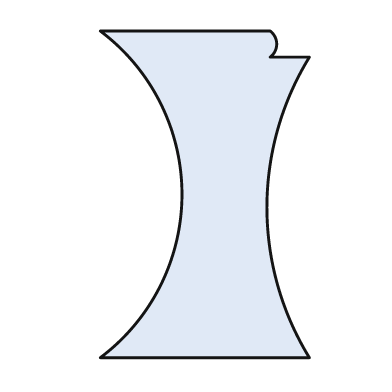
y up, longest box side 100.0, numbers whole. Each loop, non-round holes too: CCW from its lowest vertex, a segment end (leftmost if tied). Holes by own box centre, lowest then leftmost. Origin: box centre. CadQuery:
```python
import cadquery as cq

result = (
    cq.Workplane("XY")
    .moveTo(-32.0, -50.0)
    .lineTo(32.0, -50.0)
    .threePointArc((19.0, -4.0), (32.0, 42.0))
    .lineTo(20.0, 42.0)
    .threePointArc((22.0, 46.0), (20.0, 50.0))
    .lineTo(-32.0, 50.0)
    .threePointArc((-7.0, 0.0), (-32.0, -50.0))
    .close()
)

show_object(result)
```